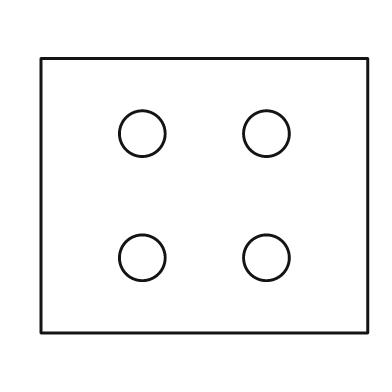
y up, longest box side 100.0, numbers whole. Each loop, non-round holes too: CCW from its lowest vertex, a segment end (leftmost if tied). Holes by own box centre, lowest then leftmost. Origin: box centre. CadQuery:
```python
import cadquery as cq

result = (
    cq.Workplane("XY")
    .moveTo(-50.0, -42.0)
    .lineTo(50.0, -42.0)
    .lineTo(50.0, 42.0)
    .lineTo(-50.0, 42.0)
    .close()
    .moveTo(-19.0, -19.0)
    .circle(7.0)
    .moveTo(19.0, -19.0)
    .circle(7.0)
    .moveTo(-19.0, 19.0)
    .circle(7.0)
    .moveTo(19.0, 19.0)
    .circle(7.0)
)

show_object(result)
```